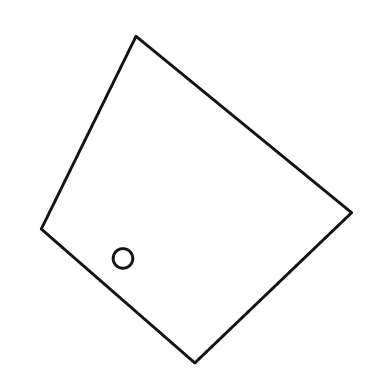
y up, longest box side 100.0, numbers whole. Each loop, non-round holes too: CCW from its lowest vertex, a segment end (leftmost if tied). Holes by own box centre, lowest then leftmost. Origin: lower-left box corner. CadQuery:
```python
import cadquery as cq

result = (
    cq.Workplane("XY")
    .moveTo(47.0, 0.0)
    .lineTo(95.0, 46.0)
    .lineTo(29.0, 100.0)
    .lineTo(0.0, 41.0)
    .close()
    .moveTo(25.0, 32.0)
    .circle(3.0)
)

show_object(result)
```